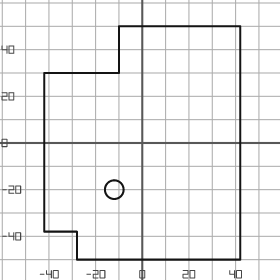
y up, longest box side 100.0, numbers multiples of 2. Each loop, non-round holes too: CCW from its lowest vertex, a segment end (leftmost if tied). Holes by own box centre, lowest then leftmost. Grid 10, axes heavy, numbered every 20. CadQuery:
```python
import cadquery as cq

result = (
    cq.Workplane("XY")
    .moveTo(-28.0, -50.0)
    .lineTo(42.0, -50.0)
    .lineTo(42.0, 50.0)
    .lineTo(-10.0, 50.0)
    .lineTo(-10.0, 30.0)
    .lineTo(-42.0, 30.0)
    .lineTo(-42.0, -38.0)
    .lineTo(-28.0, -38.0)
    .close()
    .moveTo(-12.0, -20.0)
    .circle(4.0)
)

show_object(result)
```